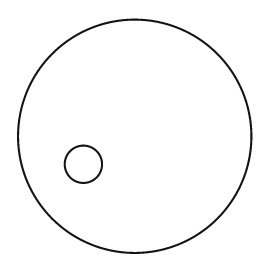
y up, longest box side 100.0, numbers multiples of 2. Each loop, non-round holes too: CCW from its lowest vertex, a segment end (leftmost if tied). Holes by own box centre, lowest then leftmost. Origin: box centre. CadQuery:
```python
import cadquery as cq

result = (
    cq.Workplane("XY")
    .moveTo(0.0, 0.0)
    .circle(50.0)
    .moveTo(-22.0, -12.0)
    .circle(8.0)
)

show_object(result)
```